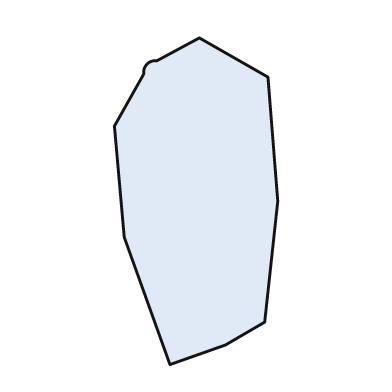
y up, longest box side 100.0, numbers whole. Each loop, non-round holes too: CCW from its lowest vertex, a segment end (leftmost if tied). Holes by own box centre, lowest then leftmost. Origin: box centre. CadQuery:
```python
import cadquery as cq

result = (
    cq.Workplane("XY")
    .moveTo(-8.0, -50.0)
    .lineTo(9.0, -44.0)
    .lineTo(21.0, -37.0)
    .lineTo(25.0, 0.0)
    .lineTo(22.0, 38.0)
    .lineTo(1.0, 50.0)
    .lineTo(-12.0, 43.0)
    .threePointArc((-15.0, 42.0), (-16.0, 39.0))
    .lineTo(-25.0, 23.0)
    .lineTo(-22.0, -11.0)
    .close()
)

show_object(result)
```